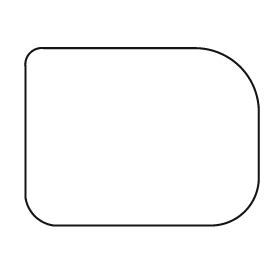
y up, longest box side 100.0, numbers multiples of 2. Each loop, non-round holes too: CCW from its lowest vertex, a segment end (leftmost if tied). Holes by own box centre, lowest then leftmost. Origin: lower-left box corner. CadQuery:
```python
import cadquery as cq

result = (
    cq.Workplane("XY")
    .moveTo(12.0, 0.0)
    .lineTo(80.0, 0.0)
    .threePointArc((94.0, 6.0), (100.0, 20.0))
    .lineTo(100.0, 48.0)
    .threePointArc((92.0, 68.0), (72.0, 76.0))
    .lineTo(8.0, 76.0)
    .threePointArc((2.0, 74.0), (0.0, 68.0))
    .lineTo(0.0, 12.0)
    .threePointArc((4.0, 4.0), (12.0, 0.0))
    .close()
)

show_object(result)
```